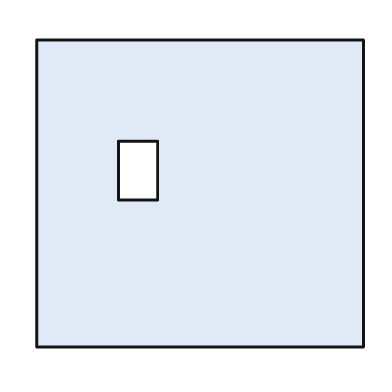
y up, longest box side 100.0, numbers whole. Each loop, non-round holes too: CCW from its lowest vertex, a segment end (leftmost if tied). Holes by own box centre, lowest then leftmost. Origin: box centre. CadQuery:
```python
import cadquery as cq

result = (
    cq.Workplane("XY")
    .moveTo(-50.0, -47.0)
    .lineTo(50.0, -47.0)
    .lineTo(50.0, 47.0)
    .lineTo(-50.0, 47.0)
    .close()
    .moveTo(-25.0, -2.0)
    .lineTo(-13.0, -2.0)
    .lineTo(-13.0, 16.0)
    .lineTo(-25.0, 16.0)
    .close()
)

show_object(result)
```